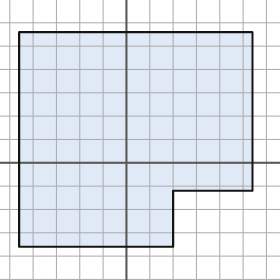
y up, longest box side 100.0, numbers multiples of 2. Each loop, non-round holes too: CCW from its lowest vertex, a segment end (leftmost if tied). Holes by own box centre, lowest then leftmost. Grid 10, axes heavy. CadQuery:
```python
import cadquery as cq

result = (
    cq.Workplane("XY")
    .moveTo(-46.0, -36.0)
    .lineTo(20.0, -36.0)
    .lineTo(20.0, -12.0)
    .lineTo(54.0, -12.0)
    .lineTo(54.0, 56.0)
    .lineTo(-46.0, 56.0)
    .close()
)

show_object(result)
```